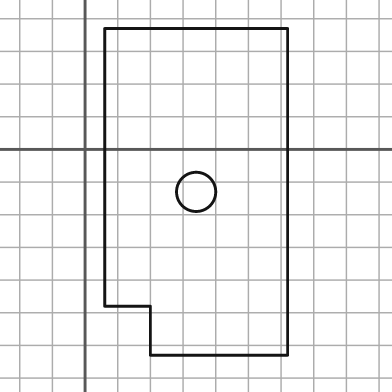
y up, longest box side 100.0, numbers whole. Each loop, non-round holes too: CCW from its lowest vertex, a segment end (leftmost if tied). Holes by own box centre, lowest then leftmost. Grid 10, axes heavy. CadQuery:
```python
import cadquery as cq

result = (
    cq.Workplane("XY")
    .moveTo(20.0, -63.0)
    .lineTo(62.0, -63.0)
    .lineTo(62.0, 37.0)
    .lineTo(6.0, 37.0)
    .lineTo(6.0, -48.0)
    .lineTo(20.0, -48.0)
    .close()
    .moveTo(34.0, -13.0)
    .circle(6.0)
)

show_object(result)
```